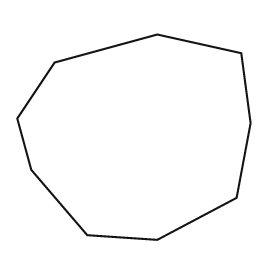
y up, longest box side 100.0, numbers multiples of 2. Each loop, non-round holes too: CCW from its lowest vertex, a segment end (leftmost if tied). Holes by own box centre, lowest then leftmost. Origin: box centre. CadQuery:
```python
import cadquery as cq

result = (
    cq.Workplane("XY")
    .moveTo(10.0, -44.0)
    .lineTo(44.0, -26.0)
    .lineTo(50.0, 6.0)
    .lineTo(46.0, 36.0)
    .lineTo(10.0, 44.0)
    .lineTo(-34.0, 32.0)
    .lineTo(-50.0, 8.0)
    .lineTo(-44.0, -14.0)
    .lineTo(-20.0, -42.0)
    .close()
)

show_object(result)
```